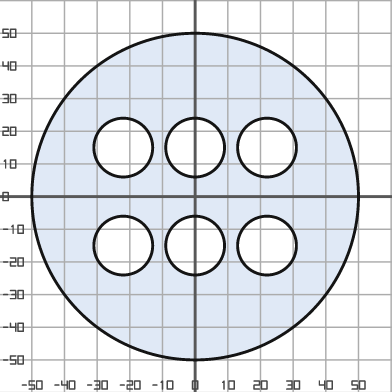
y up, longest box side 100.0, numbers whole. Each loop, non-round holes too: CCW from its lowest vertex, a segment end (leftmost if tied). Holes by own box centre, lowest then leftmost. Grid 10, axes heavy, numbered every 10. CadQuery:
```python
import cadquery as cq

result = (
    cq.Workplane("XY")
    .moveTo(0.0, 0.0)
    .circle(50.0)
    .moveTo(-22.0, -15.0)
    .circle(9.0)
    .moveTo(0.0, -15.0)
    .circle(9.0)
    .moveTo(22.0, -15.0)
    .circle(9.0)
    .moveTo(-22.0, 15.0)
    .circle(9.0)
    .moveTo(0.0, 15.0)
    .circle(9.0)
    .moveTo(22.0, 15.0)
    .circle(9.0)
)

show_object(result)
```